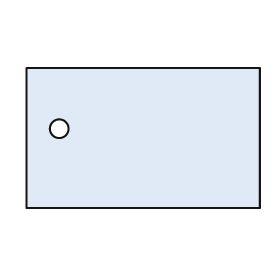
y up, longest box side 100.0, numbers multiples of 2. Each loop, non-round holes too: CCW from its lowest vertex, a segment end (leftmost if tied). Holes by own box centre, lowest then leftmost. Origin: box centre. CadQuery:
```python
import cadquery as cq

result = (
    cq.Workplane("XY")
    .moveTo(-50.0, -30.0)
    .lineTo(50.0, -30.0)
    .lineTo(50.0, 30.0)
    .lineTo(-50.0, 30.0)
    .close()
    .moveTo(-36.0, 4.0)
    .circle(4.0)
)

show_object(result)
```